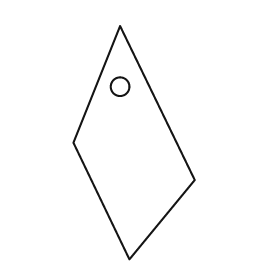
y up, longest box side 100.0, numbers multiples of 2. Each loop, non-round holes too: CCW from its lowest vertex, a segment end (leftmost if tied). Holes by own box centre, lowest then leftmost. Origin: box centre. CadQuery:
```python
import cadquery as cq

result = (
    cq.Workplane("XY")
    .moveTo(-2.0, -50.0)
    .lineTo(26.0, -16.0)
    .lineTo(-6.0, 50.0)
    .lineTo(-26.0, 0.0)
    .close()
    .moveTo(-6.0, 24.0)
    .circle(4.0)
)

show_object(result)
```